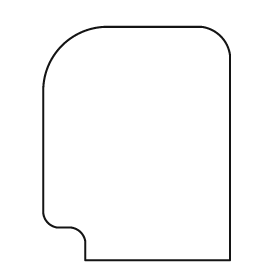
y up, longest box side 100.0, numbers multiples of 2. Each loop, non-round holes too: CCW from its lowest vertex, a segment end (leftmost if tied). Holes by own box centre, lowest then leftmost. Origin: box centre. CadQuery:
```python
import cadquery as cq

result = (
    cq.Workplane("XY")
    .moveTo(-22.0, -50.0)
    .lineTo(40.0, -50.0)
    .lineTo(40.0, 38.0)
    .threePointArc((36.0, 46.0), (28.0, 50.0))
    .lineTo(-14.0, 50.0)
    .threePointArc((-32.0, 42.0), (-40.0, 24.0))
    .lineTo(-40.0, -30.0)
    .threePointArc((-38.0, -34.0), (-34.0, -36.0))
    .lineTo(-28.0, -36.0)
    .threePointArc((-24.0, -38.0), (-22.0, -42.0))
    .close()
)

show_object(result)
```